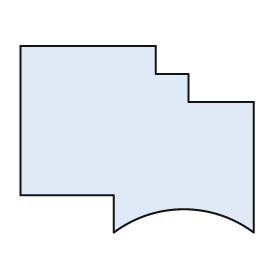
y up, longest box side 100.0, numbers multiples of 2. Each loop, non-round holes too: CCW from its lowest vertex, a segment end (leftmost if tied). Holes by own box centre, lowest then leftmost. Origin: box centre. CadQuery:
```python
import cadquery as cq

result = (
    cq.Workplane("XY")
    .moveTo(-10.0, -40.0)
    .threePointArc((20.0, -30.0), (50.0, -40.0))
    .lineTo(50.0, 16.0)
    .lineTo(22.0, 16.0)
    .lineTo(22.0, 28.0)
    .lineTo(8.0, 28.0)
    .lineTo(8.0, 40.0)
    .lineTo(-50.0, 40.0)
    .lineTo(-50.0, -24.0)
    .lineTo(-10.0, -24.0)
    .close()
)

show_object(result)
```